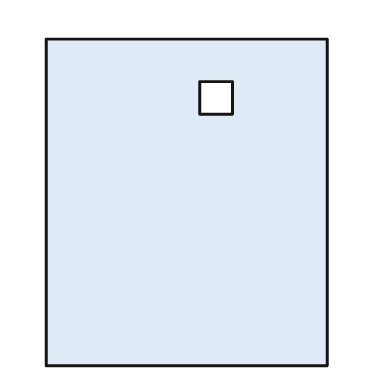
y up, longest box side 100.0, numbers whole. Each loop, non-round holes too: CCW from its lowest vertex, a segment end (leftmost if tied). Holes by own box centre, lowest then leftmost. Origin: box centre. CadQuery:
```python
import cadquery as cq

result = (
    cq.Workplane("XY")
    .moveTo(-43.0, -50.0)
    .lineTo(43.0, -50.0)
    .lineTo(43.0, 50.0)
    .lineTo(-43.0, 50.0)
    .close()
    .moveTo(4.0, 27.0)
    .lineTo(14.0, 27.0)
    .lineTo(14.0, 37.0)
    .lineTo(4.0, 37.0)
    .close()
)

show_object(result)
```